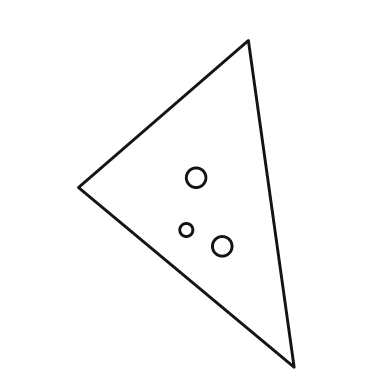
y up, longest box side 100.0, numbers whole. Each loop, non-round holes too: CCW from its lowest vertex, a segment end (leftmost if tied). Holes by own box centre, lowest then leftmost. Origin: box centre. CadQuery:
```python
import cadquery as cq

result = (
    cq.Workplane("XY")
    .moveTo(33.0, -50.0)
    .lineTo(19.0, 50.0)
    .lineTo(-33.0, 5.0)
    .close()
    .moveTo(11.0, -13.0)
    .circle(3.0)
    .moveTo(0.0, -8.0)
    .circle(2.0)
    .moveTo(3.0, 8.0)
    .circle(3.0)
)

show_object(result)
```